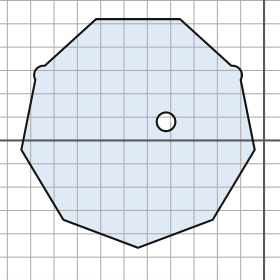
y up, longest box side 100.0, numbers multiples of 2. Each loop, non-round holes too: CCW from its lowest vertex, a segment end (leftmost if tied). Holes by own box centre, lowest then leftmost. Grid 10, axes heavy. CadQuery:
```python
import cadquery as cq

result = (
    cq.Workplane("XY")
    .moveTo(-54.0, -46.0)
    .lineTo(-22.0, -34.0)
    .lineTo(-4.0, -4.0)
    .lineTo(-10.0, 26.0)
    .threePointArc((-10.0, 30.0), (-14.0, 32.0))
    .lineTo(-36.0, 52.0)
    .lineTo(-72.0, 52.0)
    .lineTo(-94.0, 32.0)
    .threePointArc((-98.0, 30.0), (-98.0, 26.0))
    .lineTo(-104.0, -4.0)
    .lineTo(-86.0, -34.0)
    .close()
    .moveTo(-42.0, 8.0)
    .circle(4.0)
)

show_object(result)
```